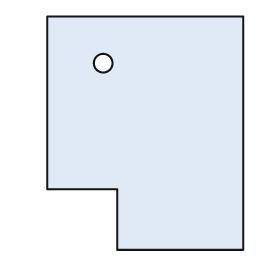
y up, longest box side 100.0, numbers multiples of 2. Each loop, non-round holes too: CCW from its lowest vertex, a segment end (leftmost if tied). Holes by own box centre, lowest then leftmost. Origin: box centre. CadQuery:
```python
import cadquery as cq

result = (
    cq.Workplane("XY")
    .moveTo(-12.0, -50.0)
    .lineTo(42.0, -50.0)
    .lineTo(42.0, 50.0)
    .lineTo(-42.0, 50.0)
    .lineTo(-42.0, -24.0)
    .lineTo(-12.0, -24.0)
    .close()
    .moveTo(-18.0, 30.0)
    .circle(4.0)
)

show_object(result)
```